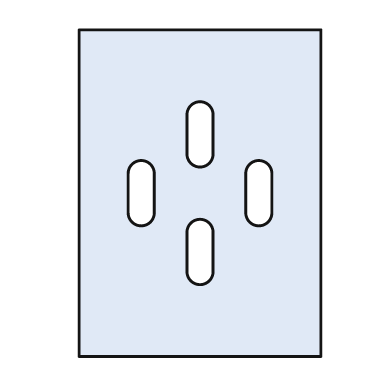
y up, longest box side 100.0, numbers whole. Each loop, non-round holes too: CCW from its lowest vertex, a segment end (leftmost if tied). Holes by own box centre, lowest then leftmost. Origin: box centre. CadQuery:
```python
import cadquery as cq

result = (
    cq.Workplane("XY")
    .moveTo(-37.0, -50.0)
    .lineTo(37.0, -50.0)
    .lineTo(37.0, 50.0)
    .lineTo(-37.0, 50.0)
    .close()
    .moveTo(-4.0, -24.0)
    .threePointArc((0.0, -28.0), (4.0, -24.0))
    .lineTo(4.0, -12.0)
    .threePointArc((0.0, -8.0), (-4.0, -12.0))
    .close()
    .moveTo(-22.0, -6.0)
    .threePointArc((-18.0, -10.0), (-14.0, -6.0))
    .lineTo(-14.0, 6.0)
    .threePointArc((-18.0, 10.0), (-22.0, 6.0))
    .close()
    .moveTo(14.0, -6.0)
    .threePointArc((18.0, -10.0), (22.0, -6.0))
    .lineTo(22.0, 6.0)
    .threePointArc((18.0, 10.0), (14.0, 6.0))
    .close()
    .moveTo(-4.0, 12.0)
    .threePointArc((0.0, 8.0), (4.0, 12.0))
    .lineTo(4.0, 24.0)
    .threePointArc((0.0, 28.0), (-4.0, 24.0))
    .close()
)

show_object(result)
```